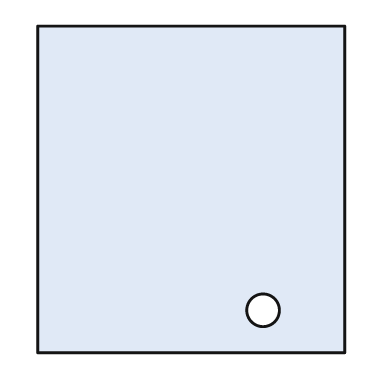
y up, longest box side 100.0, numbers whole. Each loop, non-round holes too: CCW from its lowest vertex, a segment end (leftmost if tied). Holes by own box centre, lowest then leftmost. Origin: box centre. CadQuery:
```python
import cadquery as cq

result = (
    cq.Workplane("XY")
    .moveTo(-47.0, -50.0)
    .lineTo(47.0, -50.0)
    .lineTo(47.0, 50.0)
    .lineTo(-47.0, 50.0)
    .close()
    .moveTo(22.0, -37.0)
    .circle(5.0)
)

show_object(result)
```